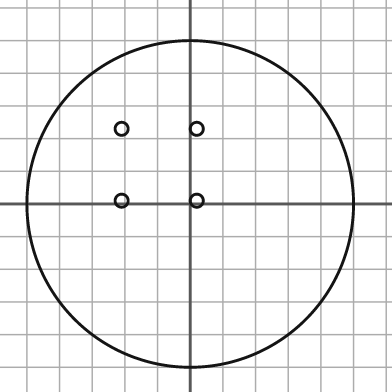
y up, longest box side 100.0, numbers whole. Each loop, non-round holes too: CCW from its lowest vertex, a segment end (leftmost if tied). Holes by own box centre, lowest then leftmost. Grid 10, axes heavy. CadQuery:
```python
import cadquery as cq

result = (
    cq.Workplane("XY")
    .moveTo(0.0, 0.0)
    .circle(50.0)
    .moveTo(-21.0, 1.0)
    .circle(2.0)
    .moveTo(2.0, 1.0)
    .circle(2.0)
    .moveTo(-21.0, 23.0)
    .circle(2.0)
    .moveTo(2.0, 23.0)
    .circle(2.0)
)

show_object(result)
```